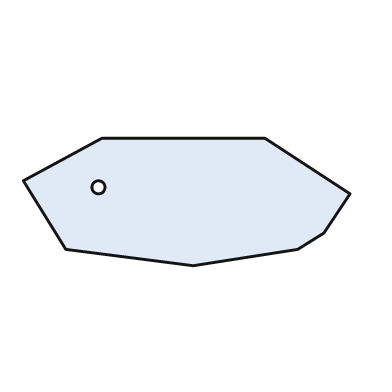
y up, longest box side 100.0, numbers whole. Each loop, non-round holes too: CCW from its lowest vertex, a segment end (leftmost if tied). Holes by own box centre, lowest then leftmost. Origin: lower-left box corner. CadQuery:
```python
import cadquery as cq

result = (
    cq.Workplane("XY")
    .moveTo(52.0, 0.0)
    .lineTo(84.0, 5.0)
    .lineTo(92.0, 10.0)
    .lineTo(100.0, 22.0)
    .lineTo(74.0, 39.0)
    .lineTo(24.0, 39.0)
    .lineTo(0.0, 26.0)
    .lineTo(13.0, 5.0)
    .close()
    .moveTo(23.0, 24.0)
    .circle(2.0)
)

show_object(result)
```